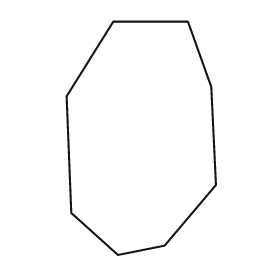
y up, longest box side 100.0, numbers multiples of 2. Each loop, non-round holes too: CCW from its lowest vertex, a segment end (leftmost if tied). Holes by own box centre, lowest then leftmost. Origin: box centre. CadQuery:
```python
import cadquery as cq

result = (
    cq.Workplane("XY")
    .moveTo(-10.0, -50.0)
    .lineTo(10.0, -46.0)
    .lineTo(32.0, -20.0)
    .lineTo(30.0, 22.0)
    .lineTo(20.0, 50.0)
    .lineTo(-12.0, 50.0)
    .lineTo(-32.0, 18.0)
    .lineTo(-30.0, -32.0)
    .close()
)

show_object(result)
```